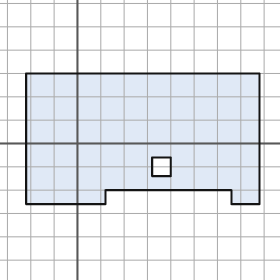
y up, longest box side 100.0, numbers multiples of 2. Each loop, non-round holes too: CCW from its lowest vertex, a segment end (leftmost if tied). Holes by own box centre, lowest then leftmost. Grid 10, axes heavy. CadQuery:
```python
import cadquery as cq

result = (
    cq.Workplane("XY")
    .moveTo(-22.0, -26.0)
    .lineTo(12.0, -26.0)
    .lineTo(12.0, -20.0)
    .lineTo(66.0, -20.0)
    .lineTo(66.0, -26.0)
    .lineTo(78.0, -26.0)
    .lineTo(78.0, 30.0)
    .lineTo(-22.0, 30.0)
    .close()
    .moveTo(32.0, -14.0)
    .lineTo(40.0, -14.0)
    .lineTo(40.0, -6.0)
    .lineTo(32.0, -6.0)
    .close()
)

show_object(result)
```